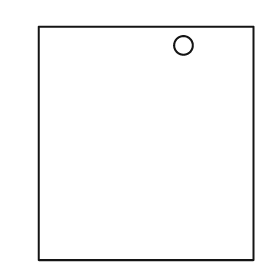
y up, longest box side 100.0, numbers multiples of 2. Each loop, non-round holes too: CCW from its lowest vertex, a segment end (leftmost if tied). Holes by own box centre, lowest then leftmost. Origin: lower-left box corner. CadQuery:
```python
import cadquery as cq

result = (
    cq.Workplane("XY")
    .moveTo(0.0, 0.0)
    .lineTo(92.0, 0.0)
    .lineTo(92.0, 100.0)
    .lineTo(0.0, 100.0)
    .close()
    .moveTo(62.0, 92.0)
    .circle(4.0)
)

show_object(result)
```